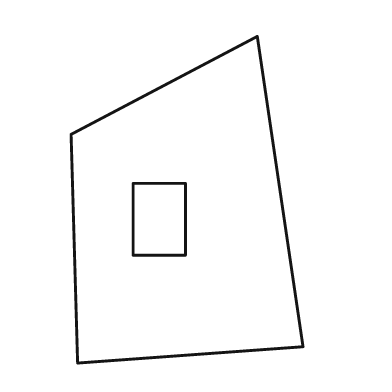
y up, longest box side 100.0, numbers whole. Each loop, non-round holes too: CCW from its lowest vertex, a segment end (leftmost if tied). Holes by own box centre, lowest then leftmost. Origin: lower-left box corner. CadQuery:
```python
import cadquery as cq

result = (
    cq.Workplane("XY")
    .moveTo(2.0, 0.0)
    .lineTo(71.0, 5.0)
    .lineTo(57.0, 100.0)
    .lineTo(0.0, 70.0)
    .close()
    .moveTo(19.0, 33.0)
    .lineTo(35.0, 33.0)
    .lineTo(35.0, 55.0)
    .lineTo(19.0, 55.0)
    .close()
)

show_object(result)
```